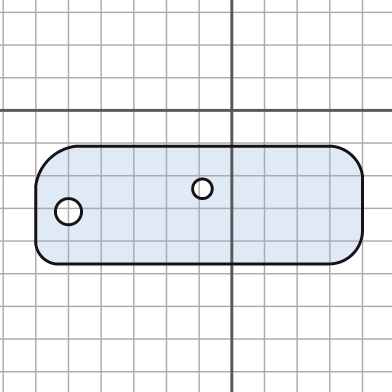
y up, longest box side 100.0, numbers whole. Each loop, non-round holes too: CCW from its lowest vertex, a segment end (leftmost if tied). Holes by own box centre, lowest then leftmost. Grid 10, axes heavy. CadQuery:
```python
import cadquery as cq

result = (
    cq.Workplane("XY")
    .moveTo(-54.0, -47.0)
    .lineTo(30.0, -47.0)
    .threePointArc((37.0, -44.0), (40.0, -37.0))
    .lineTo(40.0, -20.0)
    .threePointArc((37.0, -14.0), (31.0, -11.0))
    .lineTo(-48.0, -11.0)
    .threePointArc((-56.0, -15.0), (-60.0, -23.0))
    .lineTo(-60.0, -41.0)
    .threePointArc((-58.0, -45.0), (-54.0, -47.0))
    .close()
    .moveTo(-50.0, -31.0)
    .circle(4.0)
    .moveTo(-9.0, -24.0)
    .circle(3.0)
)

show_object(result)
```